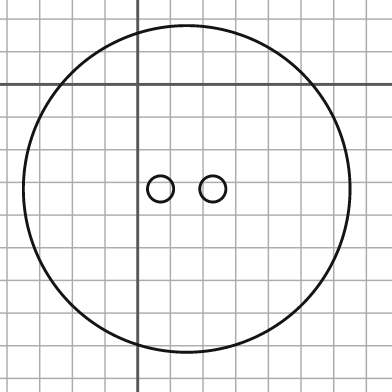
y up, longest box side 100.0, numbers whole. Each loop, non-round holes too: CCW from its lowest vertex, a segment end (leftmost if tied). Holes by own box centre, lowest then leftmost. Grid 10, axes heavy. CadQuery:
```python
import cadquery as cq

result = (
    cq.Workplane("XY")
    .moveTo(15.0, -32.0)
    .circle(50.0)
    .moveTo(7.0, -32.0)
    .circle(4.0)
    .moveTo(23.0, -32.0)
    .circle(4.0)
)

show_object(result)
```